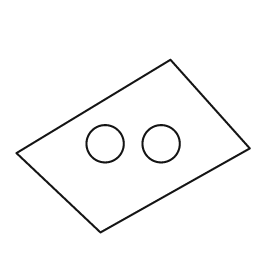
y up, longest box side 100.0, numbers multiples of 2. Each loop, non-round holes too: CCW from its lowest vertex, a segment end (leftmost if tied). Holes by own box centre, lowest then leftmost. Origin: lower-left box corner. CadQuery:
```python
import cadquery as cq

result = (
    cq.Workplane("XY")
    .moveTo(36.0, 0.0)
    .lineTo(100.0, 36.0)
    .lineTo(66.0, 74.0)
    .lineTo(0.0, 34.0)
    .close()
    .moveTo(38.0, 38.0)
    .circle(8.0)
    .moveTo(62.0, 38.0)
    .circle(8.0)
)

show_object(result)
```